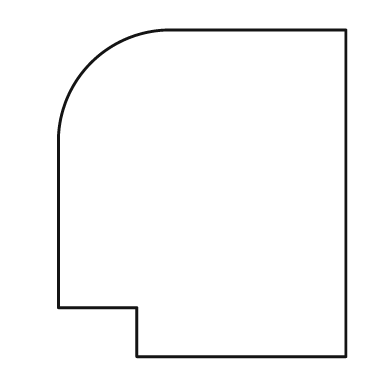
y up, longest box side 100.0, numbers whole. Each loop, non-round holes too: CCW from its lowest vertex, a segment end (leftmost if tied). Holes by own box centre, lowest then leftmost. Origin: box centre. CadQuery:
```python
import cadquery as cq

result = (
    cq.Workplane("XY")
    .moveTo(-20.0, -50.0)
    .lineTo(44.0, -50.0)
    .lineTo(44.0, 50.0)
    .lineTo(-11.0, 50.0)
    .threePointArc((-34.0, 40.0), (-44.0, 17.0))
    .lineTo(-44.0, -35.0)
    .lineTo(-20.0, -35.0)
    .close()
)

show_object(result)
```